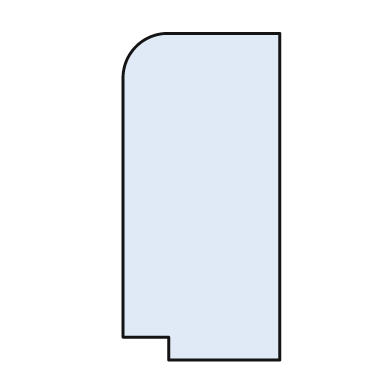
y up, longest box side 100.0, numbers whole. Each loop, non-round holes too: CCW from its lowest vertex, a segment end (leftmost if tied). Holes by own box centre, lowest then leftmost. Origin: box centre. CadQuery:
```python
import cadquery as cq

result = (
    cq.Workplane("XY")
    .moveTo(-10.0, -50.0)
    .lineTo(24.0, -50.0)
    .lineTo(24.0, 50.0)
    .lineTo(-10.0, 50.0)
    .threePointArc((-20.0, 46.0), (-24.0, 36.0))
    .lineTo(-24.0, -43.0)
    .lineTo(-10.0, -43.0)
    .close()
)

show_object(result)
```